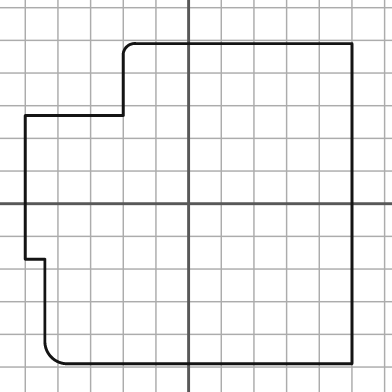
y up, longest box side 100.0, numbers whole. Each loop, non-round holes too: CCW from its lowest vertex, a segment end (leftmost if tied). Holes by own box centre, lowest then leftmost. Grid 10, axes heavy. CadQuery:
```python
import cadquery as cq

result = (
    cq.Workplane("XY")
    .moveTo(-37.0, -49.0)
    .lineTo(50.0, -49.0)
    .lineTo(50.0, 49.0)
    .lineTo(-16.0, 49.0)
    .threePointArc((-19.0, 48.0), (-20.0, 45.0))
    .lineTo(-20.0, 27.0)
    .lineTo(-50.0, 27.0)
    .lineTo(-50.0, -17.0)
    .lineTo(-44.0, -17.0)
    .lineTo(-44.0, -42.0)
    .threePointArc((-42.0, -47.0), (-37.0, -49.0))
    .close()
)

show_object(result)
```